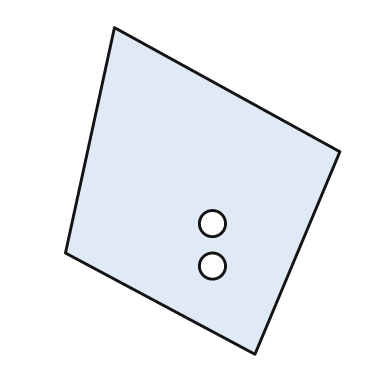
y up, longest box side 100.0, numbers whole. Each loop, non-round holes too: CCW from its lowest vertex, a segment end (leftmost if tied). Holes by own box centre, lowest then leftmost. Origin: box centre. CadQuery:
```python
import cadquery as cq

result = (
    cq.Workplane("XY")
    .moveTo(16.0, -50.0)
    .lineTo(42.0, 12.0)
    .lineTo(-27.0, 50.0)
    .lineTo(-42.0, -19.0)
    .close()
    .moveTo(3.0, -23.0)
    .circle(4.0)
    .moveTo(3.0, -10.0)
    .circle(4.0)
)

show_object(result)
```